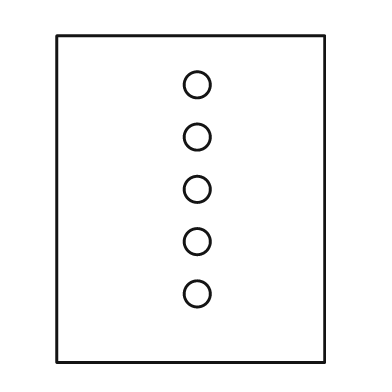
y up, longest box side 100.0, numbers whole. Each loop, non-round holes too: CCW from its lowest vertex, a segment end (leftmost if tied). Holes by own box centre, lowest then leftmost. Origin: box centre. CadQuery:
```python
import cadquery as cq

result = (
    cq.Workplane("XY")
    .moveTo(-41.0, -50.0)
    .lineTo(41.0, -50.0)
    .lineTo(41.0, 50.0)
    .lineTo(-41.0, 50.0)
    .close()
    .moveTo(2.0, -29.0)
    .circle(4.0)
    .moveTo(2.0, -13.0)
    .circle(4.0)
    .moveTo(2.0, 3.0)
    .circle(4.0)
    .moveTo(2.0, 19.0)
    .circle(4.0)
    .moveTo(2.0, 35.0)
    .circle(4.0)
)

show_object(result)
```